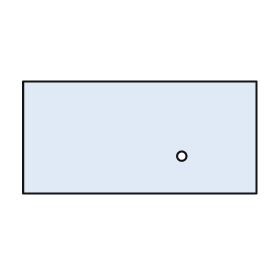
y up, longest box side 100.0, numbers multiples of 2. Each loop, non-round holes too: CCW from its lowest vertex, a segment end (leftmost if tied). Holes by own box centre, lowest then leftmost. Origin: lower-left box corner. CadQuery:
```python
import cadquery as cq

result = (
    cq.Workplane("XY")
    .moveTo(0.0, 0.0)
    .lineTo(100.0, 0.0)
    .lineTo(100.0, 48.0)
    .lineTo(0.0, 48.0)
    .close()
    .moveTo(68.0, 16.0)
    .circle(2.0)
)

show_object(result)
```